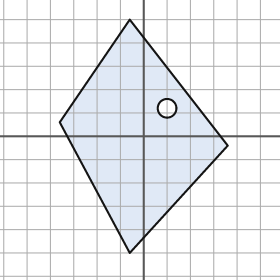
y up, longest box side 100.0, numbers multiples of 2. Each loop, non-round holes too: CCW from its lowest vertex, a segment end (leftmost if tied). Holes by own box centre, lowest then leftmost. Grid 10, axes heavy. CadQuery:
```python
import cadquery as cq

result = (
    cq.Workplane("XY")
    .moveTo(-6.0, -50.0)
    .lineTo(36.0, -4.0)
    .lineTo(-6.0, 50.0)
    .lineTo(-36.0, 6.0)
    .close()
    .moveTo(10.0, 12.0)
    .circle(4.0)
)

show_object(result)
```